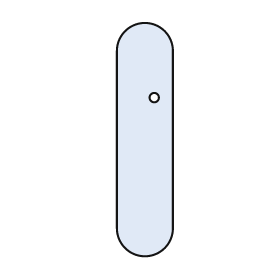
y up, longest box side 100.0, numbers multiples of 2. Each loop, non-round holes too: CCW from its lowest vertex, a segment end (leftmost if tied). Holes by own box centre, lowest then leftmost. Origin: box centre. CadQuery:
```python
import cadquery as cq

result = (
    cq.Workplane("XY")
    .moveTo(-12.0, -38.0)
    .threePointArc((0.0, -50.0), (12.0, -38.0))
    .lineTo(12.0, 38.0)
    .threePointArc((0.0, 50.0), (-12.0, 38.0))
    .close()
    .moveTo(4.0, 18.0)
    .circle(2.0)
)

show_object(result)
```